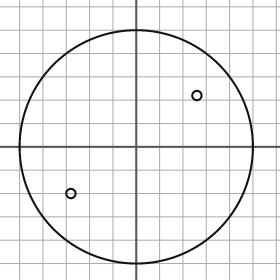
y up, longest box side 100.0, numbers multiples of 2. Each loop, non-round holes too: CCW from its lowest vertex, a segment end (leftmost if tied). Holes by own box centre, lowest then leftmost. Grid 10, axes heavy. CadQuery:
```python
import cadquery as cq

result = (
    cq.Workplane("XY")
    .moveTo(0.0, 0.0)
    .circle(50.0)
    .moveTo(-28.0, -20.0)
    .circle(2.0)
    .moveTo(26.0, 22.0)
    .circle(2.0)
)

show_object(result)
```